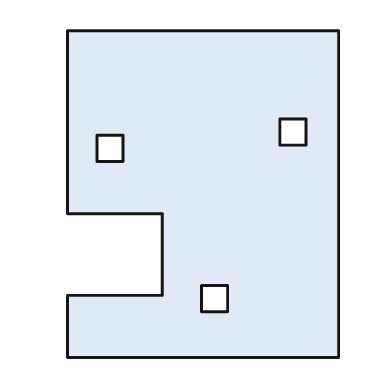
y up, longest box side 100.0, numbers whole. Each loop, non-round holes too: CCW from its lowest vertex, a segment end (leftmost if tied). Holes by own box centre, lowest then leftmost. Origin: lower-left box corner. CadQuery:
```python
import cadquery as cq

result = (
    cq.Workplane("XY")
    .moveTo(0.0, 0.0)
    .lineTo(83.0, 0.0)
    .lineTo(83.0, 100.0)
    .lineTo(0.0, 100.0)
    .lineTo(0.0, 44.0)
    .lineTo(29.0, 44.0)
    .lineTo(29.0, 19.0)
    .lineTo(0.0, 19.0)
    .close()
    .moveTo(41.0, 14.0)
    .lineTo(49.0, 14.0)
    .lineTo(49.0, 22.0)
    .lineTo(41.0, 22.0)
    .close()
    .moveTo(9.0, 60.0)
    .lineTo(17.0, 60.0)
    .lineTo(17.0, 68.0)
    .lineTo(9.0, 68.0)
    .close()
    .moveTo(65.0, 65.0)
    .lineTo(73.0, 65.0)
    .lineTo(73.0, 73.0)
    .lineTo(65.0, 73.0)
    .close()
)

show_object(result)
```